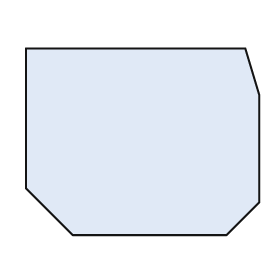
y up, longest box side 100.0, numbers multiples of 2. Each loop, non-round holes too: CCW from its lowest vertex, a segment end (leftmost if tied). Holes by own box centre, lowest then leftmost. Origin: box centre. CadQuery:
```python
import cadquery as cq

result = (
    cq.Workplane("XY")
    .moveTo(-30.0, -40.0)
    .lineTo(36.0, -40.0)
    .lineTo(50.0, -26.0)
    .lineTo(50.0, 20.0)
    .lineTo(44.0, 40.0)
    .lineTo(-50.0, 40.0)
    .lineTo(-50.0, -20.0)
    .close()
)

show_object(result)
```